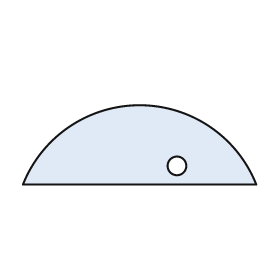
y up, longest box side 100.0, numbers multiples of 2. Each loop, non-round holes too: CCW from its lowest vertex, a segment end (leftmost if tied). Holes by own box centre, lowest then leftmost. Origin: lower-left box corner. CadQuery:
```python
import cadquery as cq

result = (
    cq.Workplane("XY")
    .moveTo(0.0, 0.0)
    .lineTo(100.0, 0.0)
    .threePointArc((50.0, 34.0), (0.0, 0.0))
    .close()
    .moveTo(66.0, 8.0)
    .circle(4.0)
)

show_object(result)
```